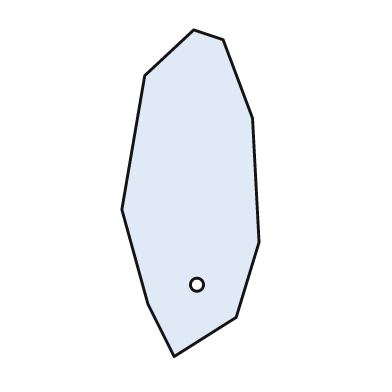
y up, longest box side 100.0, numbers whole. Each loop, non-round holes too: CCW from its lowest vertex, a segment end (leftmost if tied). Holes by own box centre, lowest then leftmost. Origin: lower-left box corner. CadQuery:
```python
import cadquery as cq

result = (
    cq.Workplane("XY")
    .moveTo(16.0, 0.0)
    .lineTo(35.0, 12.0)
    .lineTo(42.0, 35.0)
    .lineTo(40.0, 73.0)
    .lineTo(31.0, 97.0)
    .lineTo(22.0, 100.0)
    .lineTo(7.0, 86.0)
    .lineTo(0.0, 45.0)
    .lineTo(8.0, 16.0)
    .close()
    .moveTo(23.0, 22.0)
    .circle(2.0)
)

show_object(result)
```